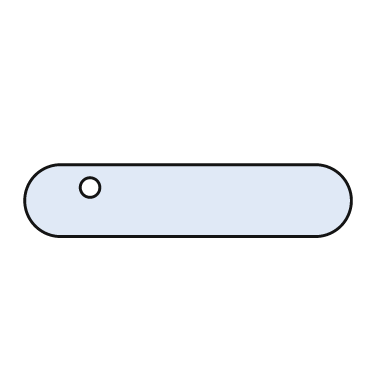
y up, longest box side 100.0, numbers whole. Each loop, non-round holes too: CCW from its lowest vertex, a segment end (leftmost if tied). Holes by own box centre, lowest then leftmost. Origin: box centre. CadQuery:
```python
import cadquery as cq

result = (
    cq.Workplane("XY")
    .moveTo(-39.0, -11.0)
    .lineTo(39.0, -11.0)
    .threePointArc((50.0, 0.0), (39.0, 11.0))
    .lineTo(-39.0, 11.0)
    .threePointArc((-50.0, 0.0), (-39.0, -11.0))
    .close()
    .moveTo(-30.0, 4.0)
    .circle(3.0)
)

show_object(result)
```